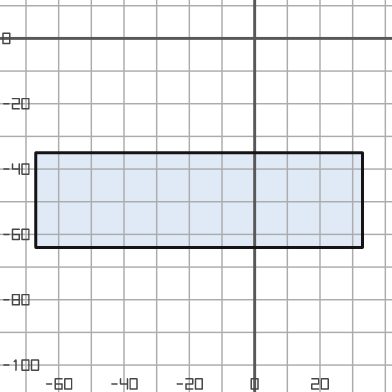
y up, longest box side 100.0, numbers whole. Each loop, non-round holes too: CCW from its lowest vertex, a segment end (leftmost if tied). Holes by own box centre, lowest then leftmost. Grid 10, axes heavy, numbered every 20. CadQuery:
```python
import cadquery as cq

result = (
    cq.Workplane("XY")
    .moveTo(-67.0, -64.0)
    .lineTo(33.0, -64.0)
    .lineTo(33.0, -35.0)
    .lineTo(-67.0, -35.0)
    .close()
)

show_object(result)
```